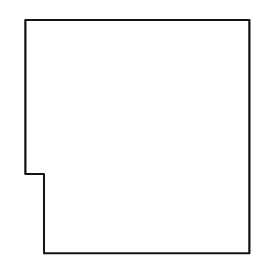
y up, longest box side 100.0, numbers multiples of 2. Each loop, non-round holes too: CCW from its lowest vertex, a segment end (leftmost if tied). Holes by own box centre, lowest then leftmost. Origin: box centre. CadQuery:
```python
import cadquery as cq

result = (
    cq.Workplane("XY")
    .moveTo(-40.0, -50.0)
    .lineTo(48.0, -50.0)
    .lineTo(48.0, 50.0)
    .lineTo(-48.0, 50.0)
    .lineTo(-48.0, -16.0)
    .lineTo(-40.0, -16.0)
    .close()
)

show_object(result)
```